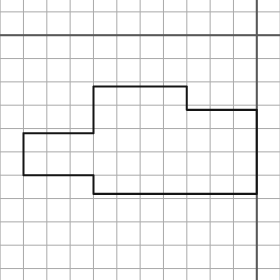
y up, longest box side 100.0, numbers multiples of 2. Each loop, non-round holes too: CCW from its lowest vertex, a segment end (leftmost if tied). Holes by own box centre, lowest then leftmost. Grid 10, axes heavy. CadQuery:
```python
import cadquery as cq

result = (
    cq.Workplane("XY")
    .moveTo(-70.0, -68.0)
    .lineTo(0.0, -68.0)
    .lineTo(0.0, -32.0)
    .lineTo(-30.0, -32.0)
    .lineTo(-30.0, -22.0)
    .lineTo(-70.0, -22.0)
    .lineTo(-70.0, -42.0)
    .lineTo(-100.0, -42.0)
    .lineTo(-100.0, -60.0)
    .lineTo(-70.0, -60.0)
    .close()
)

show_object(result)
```